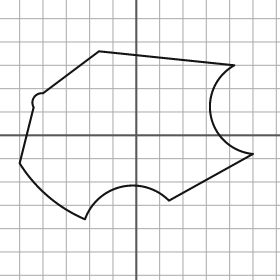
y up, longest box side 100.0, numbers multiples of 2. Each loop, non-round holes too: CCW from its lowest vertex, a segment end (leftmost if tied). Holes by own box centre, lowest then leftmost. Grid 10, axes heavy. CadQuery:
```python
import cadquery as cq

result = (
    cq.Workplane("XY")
    .moveTo(-22.0, -36.0)
    .threePointArc((-6.0, -22.0), (14.0, -28.0))
    .lineTo(50.0, -8.0)
    .threePointArc((32.0, 8.0), (42.0, 30.0))
    .lineTo(-16.0, 36.0)
    .lineTo(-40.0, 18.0)
    .threePointArc((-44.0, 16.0), (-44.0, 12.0))
    .lineTo(-50.0, -12.0)
    .threePointArc((-38.0, -26.0), (-22.0, -36.0))
    .close()
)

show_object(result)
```